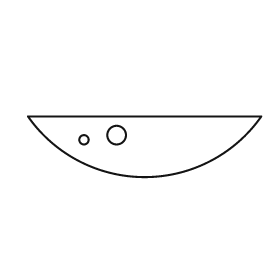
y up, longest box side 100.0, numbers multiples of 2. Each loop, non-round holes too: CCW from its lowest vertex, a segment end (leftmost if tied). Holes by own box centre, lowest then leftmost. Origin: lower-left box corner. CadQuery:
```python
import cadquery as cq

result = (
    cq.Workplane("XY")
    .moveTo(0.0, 26.0)
    .threePointArc((50.0, 0.0), (100.0, 26.0))
    .close()
    .moveTo(24.0, 16.0)
    .circle(2.0)
    .moveTo(38.0, 18.0)
    .circle(4.0)
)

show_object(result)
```